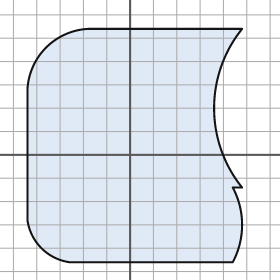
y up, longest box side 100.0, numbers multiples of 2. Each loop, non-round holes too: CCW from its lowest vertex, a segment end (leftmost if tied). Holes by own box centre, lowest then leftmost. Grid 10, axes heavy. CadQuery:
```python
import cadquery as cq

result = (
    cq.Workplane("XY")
    .moveTo(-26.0, -46.0)
    .lineTo(44.0, -46.0)
    .threePointArc((48.0, -30.0), (44.0, -14.0))
    .lineTo(48.0, -14.0)
    .threePointArc((36.0, 20.0), (48.0, 54.0))
    .lineTo(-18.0, 54.0)
    .threePointArc((-36.0, 46.0), (-44.0, 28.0))
    .lineTo(-44.0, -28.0)
    .threePointArc((-38.0, -40.0), (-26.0, -46.0))
    .close()
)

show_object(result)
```